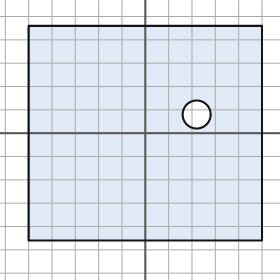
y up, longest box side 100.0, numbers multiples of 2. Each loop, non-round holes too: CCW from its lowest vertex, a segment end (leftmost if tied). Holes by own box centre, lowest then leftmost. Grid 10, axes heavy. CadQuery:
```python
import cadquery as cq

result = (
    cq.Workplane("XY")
    .moveTo(-50.0, -46.0)
    .lineTo(50.0, -46.0)
    .lineTo(50.0, 46.0)
    .lineTo(-50.0, 46.0)
    .close()
    .moveTo(22.0, 8.0)
    .circle(6.0)
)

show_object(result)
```